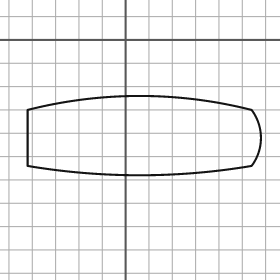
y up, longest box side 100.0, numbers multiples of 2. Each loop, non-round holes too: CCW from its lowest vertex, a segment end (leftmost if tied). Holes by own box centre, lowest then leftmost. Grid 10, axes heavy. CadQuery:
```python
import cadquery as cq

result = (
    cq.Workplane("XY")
    .moveTo(-42.0, -54.0)
    .threePointArc((6.0, -58.0), (54.0, -54.0))
    .threePointArc((58.0, -42.0), (54.0, -30.0))
    .threePointArc((6.0, -24.0), (-42.0, -30.0))
    .close()
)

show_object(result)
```